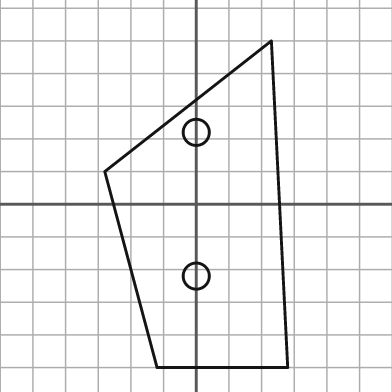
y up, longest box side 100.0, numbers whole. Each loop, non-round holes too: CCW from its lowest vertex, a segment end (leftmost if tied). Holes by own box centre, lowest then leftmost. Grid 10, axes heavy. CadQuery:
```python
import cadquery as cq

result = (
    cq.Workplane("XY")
    .moveTo(-12.0, -50.0)
    .lineTo(28.0, -50.0)
    .lineTo(23.0, 50.0)
    .lineTo(-28.0, 10.0)
    .close()
    .moveTo(0.0, -22.0)
    .circle(4.0)
    .moveTo(0.0, 22.0)
    .circle(4.0)
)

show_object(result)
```